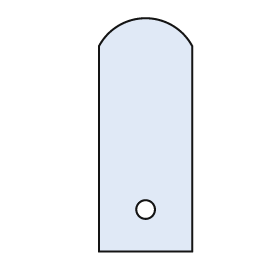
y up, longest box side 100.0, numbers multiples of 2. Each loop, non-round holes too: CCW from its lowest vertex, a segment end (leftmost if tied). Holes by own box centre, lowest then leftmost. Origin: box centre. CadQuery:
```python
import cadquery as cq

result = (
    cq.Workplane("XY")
    .moveTo(-20.0, -50.0)
    .lineTo(20.0, -50.0)
    .lineTo(20.0, 38.0)
    .threePointArc((0.0, 50.0), (-20.0, 38.0))
    .close()
    .moveTo(0.0, -32.0)
    .circle(4.0)
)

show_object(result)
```